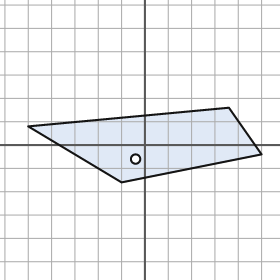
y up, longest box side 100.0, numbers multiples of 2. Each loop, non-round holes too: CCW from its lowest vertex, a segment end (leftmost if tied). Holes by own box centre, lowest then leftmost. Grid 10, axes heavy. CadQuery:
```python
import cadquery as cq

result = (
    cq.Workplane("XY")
    .moveTo(-10.0, -16.0)
    .lineTo(50.0, -4.0)
    .lineTo(36.0, 16.0)
    .lineTo(-50.0, 8.0)
    .close()
    .moveTo(-4.0, -6.0)
    .circle(2.0)
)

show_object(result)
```